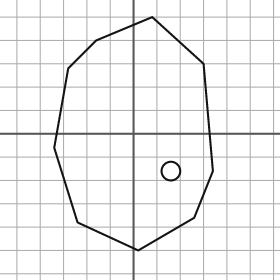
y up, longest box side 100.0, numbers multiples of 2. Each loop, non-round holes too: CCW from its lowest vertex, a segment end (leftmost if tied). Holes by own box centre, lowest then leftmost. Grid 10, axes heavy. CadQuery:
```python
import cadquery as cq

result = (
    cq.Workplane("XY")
    .moveTo(2.0, -50.0)
    .lineTo(26.0, -36.0)
    .lineTo(34.0, -16.0)
    .lineTo(30.0, 30.0)
    .lineTo(8.0, 50.0)
    .lineTo(-16.0, 40.0)
    .lineTo(-28.0, 28.0)
    .lineTo(-34.0, -6.0)
    .lineTo(-24.0, -38.0)
    .close()
    .moveTo(16.0, -16.0)
    .circle(4.0)
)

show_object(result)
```